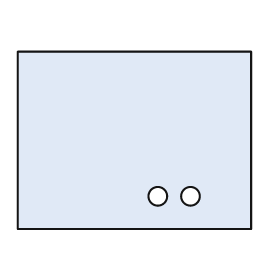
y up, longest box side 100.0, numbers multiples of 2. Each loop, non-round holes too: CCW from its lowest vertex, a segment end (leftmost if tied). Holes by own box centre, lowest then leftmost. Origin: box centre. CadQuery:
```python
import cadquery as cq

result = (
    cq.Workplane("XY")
    .moveTo(-50.0, -38.0)
    .lineTo(50.0, -38.0)
    .lineTo(50.0, 38.0)
    .lineTo(-50.0, 38.0)
    .close()
    .moveTo(10.0, -24.0)
    .circle(4.0)
    .moveTo(24.0, -24.0)
    .circle(4.0)
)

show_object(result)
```